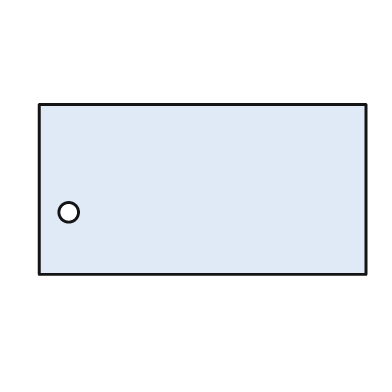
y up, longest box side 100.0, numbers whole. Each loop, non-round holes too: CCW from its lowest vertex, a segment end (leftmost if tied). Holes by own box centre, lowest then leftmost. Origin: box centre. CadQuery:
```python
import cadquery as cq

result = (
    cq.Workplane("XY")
    .moveTo(-50.0, -26.0)
    .lineTo(50.0, -26.0)
    .lineTo(50.0, 26.0)
    .lineTo(-50.0, 26.0)
    .close()
    .moveTo(-41.0, -7.0)
    .circle(3.0)
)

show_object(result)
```